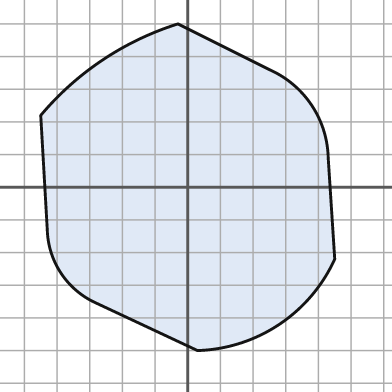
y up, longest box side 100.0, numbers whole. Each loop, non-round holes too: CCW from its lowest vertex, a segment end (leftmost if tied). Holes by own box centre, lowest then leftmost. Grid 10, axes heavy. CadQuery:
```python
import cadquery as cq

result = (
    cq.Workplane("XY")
    .moveTo(3.0, -50.0)
    .threePointArc((28.0, -42.0), (45.0, -22.0))
    .lineTo(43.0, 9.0)
    .threePointArc((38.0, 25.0), (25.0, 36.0))
    .lineTo(-3.0, 50.0)
    .threePointArc((-26.0, 39.0), (-45.0, 22.0))
    .lineTo(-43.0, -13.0)
    .threePointArc((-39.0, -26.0), (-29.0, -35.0))
    .close()
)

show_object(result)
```